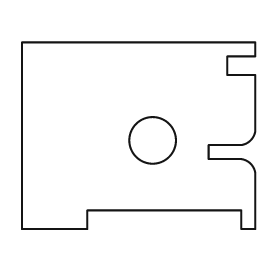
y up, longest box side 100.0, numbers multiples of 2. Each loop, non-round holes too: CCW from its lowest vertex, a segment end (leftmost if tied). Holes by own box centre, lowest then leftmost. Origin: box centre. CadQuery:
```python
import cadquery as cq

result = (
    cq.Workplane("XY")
    .moveTo(-50.0, -40.0)
    .lineTo(-22.0, -40.0)
    .lineTo(-22.0, -32.0)
    .lineTo(44.0, -32.0)
    .lineTo(44.0, -40.0)
    .lineTo(50.0, -40.0)
    .lineTo(50.0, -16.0)
    .threePointArc((48.0, -12.0), (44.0, -10.0))
    .lineTo(30.0, -10.0)
    .lineTo(30.0, -4.0)
    .lineTo(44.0, -4.0)
    .threePointArc((48.0, -2.0), (50.0, 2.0))
    .lineTo(50.0, 26.0)
    .lineTo(38.0, 26.0)
    .lineTo(38.0, 34.0)
    .lineTo(50.0, 34.0)
    .lineTo(50.0, 40.0)
    .lineTo(-50.0, 40.0)
    .close()
    .moveTo(6.0, -2.0)
    .circle(10.0)
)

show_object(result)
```